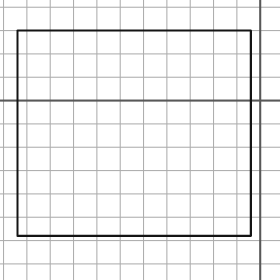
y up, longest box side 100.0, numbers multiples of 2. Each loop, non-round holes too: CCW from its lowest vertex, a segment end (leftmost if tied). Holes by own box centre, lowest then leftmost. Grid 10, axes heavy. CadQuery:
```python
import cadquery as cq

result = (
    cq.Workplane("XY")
    .moveTo(-104.0, -58.0)
    .lineTo(-4.0, -58.0)
    .lineTo(-4.0, 30.0)
    .lineTo(-104.0, 30.0)
    .close()
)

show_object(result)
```